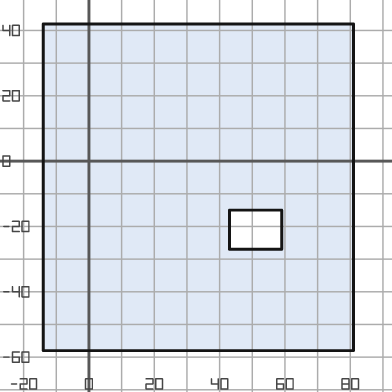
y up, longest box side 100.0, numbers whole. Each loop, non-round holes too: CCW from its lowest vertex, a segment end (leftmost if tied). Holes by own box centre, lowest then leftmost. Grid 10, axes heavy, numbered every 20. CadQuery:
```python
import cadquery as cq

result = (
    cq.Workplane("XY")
    .moveTo(-14.0, -58.0)
    .lineTo(81.0, -58.0)
    .lineTo(81.0, 42.0)
    .lineTo(-14.0, 42.0)
    .close()
    .moveTo(43.0, -27.0)
    .lineTo(59.0, -27.0)
    .lineTo(59.0, -15.0)
    .lineTo(43.0, -15.0)
    .close()
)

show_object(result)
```